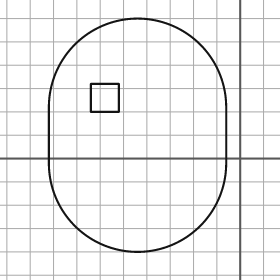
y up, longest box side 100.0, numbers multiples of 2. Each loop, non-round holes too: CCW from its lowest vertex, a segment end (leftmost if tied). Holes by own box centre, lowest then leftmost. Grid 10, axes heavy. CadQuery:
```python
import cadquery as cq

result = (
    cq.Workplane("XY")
    .moveTo(-82.0, -2.0)
    .threePointArc((-44.0, -40.0), (-6.0, -2.0))
    .lineTo(-6.0, 22.0)
    .threePointArc((-44.0, 60.0), (-82.0, 22.0))
    .close()
    .moveTo(-64.0, 20.0)
    .lineTo(-52.0, 20.0)
    .lineTo(-52.0, 32.0)
    .lineTo(-64.0, 32.0)
    .close()
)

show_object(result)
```